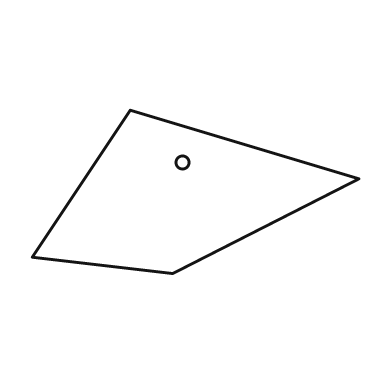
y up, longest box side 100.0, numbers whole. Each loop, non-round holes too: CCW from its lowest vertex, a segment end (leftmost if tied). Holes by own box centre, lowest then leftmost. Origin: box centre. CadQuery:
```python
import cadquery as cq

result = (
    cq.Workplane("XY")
    .moveTo(-7.0, -25.0)
    .lineTo(50.0, 4.0)
    .lineTo(-20.0, 25.0)
    .lineTo(-50.0, -20.0)
    .close()
    .moveTo(-4.0, 9.0)
    .circle(2.0)
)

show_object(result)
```